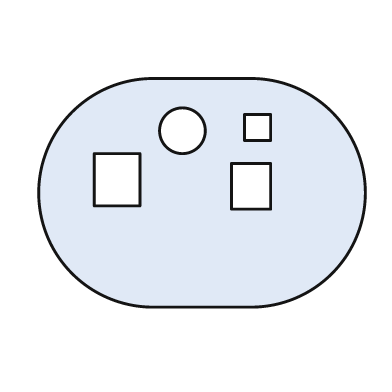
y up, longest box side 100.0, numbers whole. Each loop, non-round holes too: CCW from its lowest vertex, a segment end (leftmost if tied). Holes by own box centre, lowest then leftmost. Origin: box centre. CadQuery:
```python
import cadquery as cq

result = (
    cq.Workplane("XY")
    .moveTo(-15.0, -35.0)
    .lineTo(15.0, -35.0)
    .threePointArc((50.0, 0.0), (15.0, 35.0))
    .lineTo(-15.0, 35.0)
    .threePointArc((-50.0, 0.0), (-15.0, -35.0))
    .close()
    .moveTo(9.0, -5.0)
    .lineTo(21.0, -5.0)
    .lineTo(21.0, 9.0)
    .lineTo(9.0, 9.0)
    .close()
    .moveTo(-33.0, -4.0)
    .lineTo(-19.0, -4.0)
    .lineTo(-19.0, 12.0)
    .lineTo(-33.0, 12.0)
    .close()
    .moveTo(-6.0, 19.0)
    .circle(7.0)
    .moveTo(13.0, 16.0)
    .lineTo(21.0, 16.0)
    .lineTo(21.0, 24.0)
    .lineTo(13.0, 24.0)
    .close()
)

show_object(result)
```